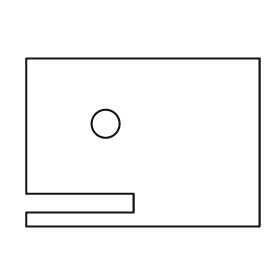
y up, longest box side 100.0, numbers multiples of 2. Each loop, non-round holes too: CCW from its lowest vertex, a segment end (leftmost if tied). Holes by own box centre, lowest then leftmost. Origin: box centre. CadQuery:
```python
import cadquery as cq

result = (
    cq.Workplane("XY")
    .moveTo(-50.0, -36.0)
    .lineTo(50.0, -36.0)
    .lineTo(50.0, 36.0)
    .lineTo(-50.0, 36.0)
    .lineTo(-50.0, -22.0)
    .lineTo(-4.0, -22.0)
    .lineTo(-4.0, -30.0)
    .lineTo(-50.0, -30.0)
    .close()
    .moveTo(-16.0, 8.0)
    .circle(6.0)
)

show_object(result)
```